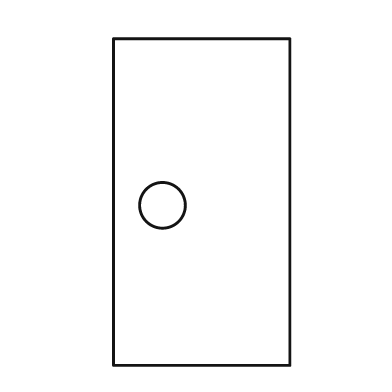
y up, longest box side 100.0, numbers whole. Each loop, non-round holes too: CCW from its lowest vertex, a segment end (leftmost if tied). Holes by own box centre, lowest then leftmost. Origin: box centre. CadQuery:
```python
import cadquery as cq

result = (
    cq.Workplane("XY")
    .moveTo(-27.0, -50.0)
    .lineTo(27.0, -50.0)
    .lineTo(27.0, 50.0)
    .lineTo(-27.0, 50.0)
    .close()
    .moveTo(-12.0, -1.0)
    .circle(7.0)
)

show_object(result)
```